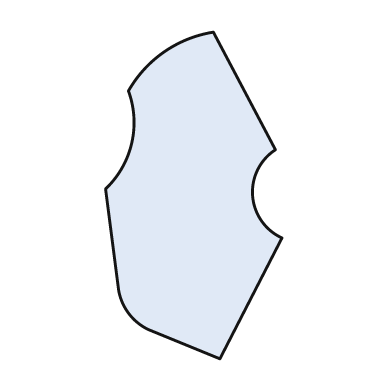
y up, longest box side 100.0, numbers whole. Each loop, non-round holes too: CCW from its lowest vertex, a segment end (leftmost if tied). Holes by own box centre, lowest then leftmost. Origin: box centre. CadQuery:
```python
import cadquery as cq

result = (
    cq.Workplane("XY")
    .moveTo(8.0, -50.0)
    .lineTo(27.0, -13.0)
    .threePointArc((18.0, 0.0), (25.0, 14.0))
    .lineTo(6.0, 50.0)
    .threePointArc((-9.0, 44.0), (-20.0, 32.0))
    .threePointArc((-19.0, 16.0), (-27.0, 2.0))
    .lineTo(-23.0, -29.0)
    .threePointArc((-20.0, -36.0), (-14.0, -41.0))
    .close()
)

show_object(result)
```